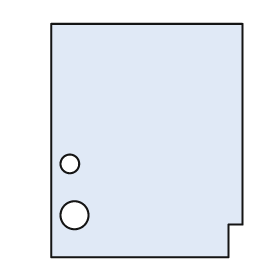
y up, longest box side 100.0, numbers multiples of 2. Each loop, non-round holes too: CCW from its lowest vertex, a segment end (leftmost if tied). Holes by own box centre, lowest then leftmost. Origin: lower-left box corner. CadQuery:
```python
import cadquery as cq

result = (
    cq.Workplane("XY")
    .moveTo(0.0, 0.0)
    .lineTo(76.0, 0.0)
    .lineTo(76.0, 14.0)
    .lineTo(82.0, 14.0)
    .lineTo(82.0, 100.0)
    .lineTo(0.0, 100.0)
    .close()
    .moveTo(10.0, 18.0)
    .circle(6.0)
    .moveTo(8.0, 40.0)
    .circle(4.0)
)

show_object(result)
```